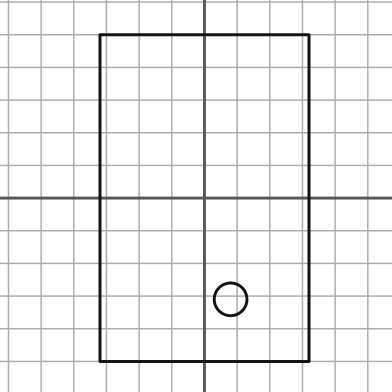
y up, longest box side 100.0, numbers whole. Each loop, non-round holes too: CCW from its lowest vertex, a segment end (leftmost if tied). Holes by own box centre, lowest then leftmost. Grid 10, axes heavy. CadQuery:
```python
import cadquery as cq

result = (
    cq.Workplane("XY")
    .moveTo(-32.0, -50.0)
    .lineTo(32.0, -50.0)
    .lineTo(32.0, 50.0)
    .lineTo(-32.0, 50.0)
    .close()
    .moveTo(8.0, -31.0)
    .circle(5.0)
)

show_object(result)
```